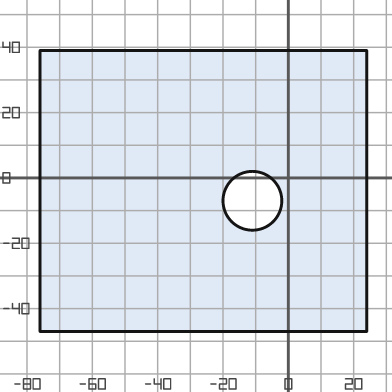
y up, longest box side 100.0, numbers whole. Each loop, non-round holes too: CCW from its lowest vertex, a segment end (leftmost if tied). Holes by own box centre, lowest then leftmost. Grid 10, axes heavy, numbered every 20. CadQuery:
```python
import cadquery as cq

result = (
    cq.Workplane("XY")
    .moveTo(-76.0, -47.0)
    .lineTo(24.0, -47.0)
    .lineTo(24.0, 39.0)
    .lineTo(-76.0, 39.0)
    .close()
    .moveTo(-11.0, -7.0)
    .circle(9.0)
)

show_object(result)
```